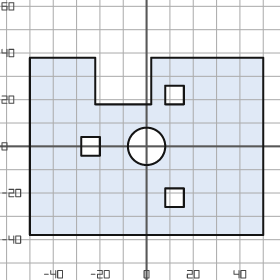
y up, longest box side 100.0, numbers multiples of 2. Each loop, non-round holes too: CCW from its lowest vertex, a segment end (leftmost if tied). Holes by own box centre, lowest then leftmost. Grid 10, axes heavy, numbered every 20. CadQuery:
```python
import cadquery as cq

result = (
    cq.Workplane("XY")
    .moveTo(-50.0, -38.0)
    .lineTo(50.0, -38.0)
    .lineTo(50.0, 38.0)
    .lineTo(2.0, 38.0)
    .lineTo(2.0, 18.0)
    .lineTo(-22.0, 18.0)
    .lineTo(-22.0, 38.0)
    .lineTo(-50.0, 38.0)
    .close()
    .moveTo(8.0, -26.0)
    .lineTo(16.0, -26.0)
    .lineTo(16.0, -18.0)
    .lineTo(8.0, -18.0)
    .close()
    .moveTo(-28.0, -4.0)
    .lineTo(-20.0, -4.0)
    .lineTo(-20.0, 4.0)
    .lineTo(-28.0, 4.0)
    .close()
    .moveTo(0.0, 0.0)
    .circle(8.0)
    .moveTo(8.0, 18.0)
    .lineTo(16.0, 18.0)
    .lineTo(16.0, 26.0)
    .lineTo(8.0, 26.0)
    .close()
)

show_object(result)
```